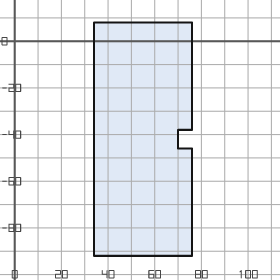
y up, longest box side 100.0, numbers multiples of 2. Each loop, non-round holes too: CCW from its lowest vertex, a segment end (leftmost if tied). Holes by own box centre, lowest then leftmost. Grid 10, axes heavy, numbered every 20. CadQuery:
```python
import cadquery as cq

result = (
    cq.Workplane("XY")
    .moveTo(34.0, -92.0)
    .lineTo(76.0, -92.0)
    .lineTo(76.0, -46.0)
    .lineTo(70.0, -46.0)
    .lineTo(70.0, -38.0)
    .lineTo(76.0, -38.0)
    .lineTo(76.0, 8.0)
    .lineTo(34.0, 8.0)
    .close()
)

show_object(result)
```